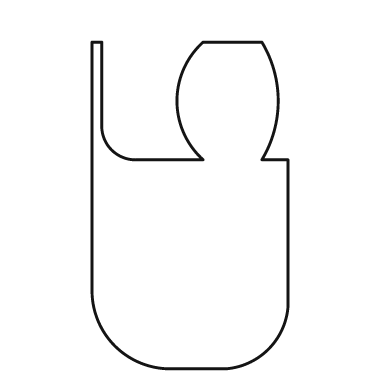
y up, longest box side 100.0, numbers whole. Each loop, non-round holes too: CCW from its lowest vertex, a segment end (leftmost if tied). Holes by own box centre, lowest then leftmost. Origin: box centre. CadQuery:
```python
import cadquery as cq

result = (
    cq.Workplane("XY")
    .moveTo(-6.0, -50.0)
    .lineTo(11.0, -50.0)
    .threePointArc((24.0, -44.0), (30.0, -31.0))
    .lineTo(30.0, 14.0)
    .lineTo(22.0, 14.0)
    .threePointArc((27.0, 32.0), (22.0, 50.0))
    .lineTo(4.0, 50.0)
    .threePointArc((-4.0, 32.0), (4.0, 14.0))
    .lineTo(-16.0, 14.0)
    .threePointArc((-24.0, 17.0), (-27.0, 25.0))
    .lineTo(-27.0, 50.0)
    .lineTo(-30.0, 50.0)
    .lineTo(-30.0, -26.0)
    .threePointArc((-23.0, -43.0), (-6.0, -50.0))
    .close()
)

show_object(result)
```